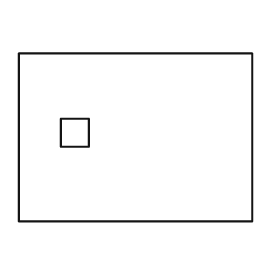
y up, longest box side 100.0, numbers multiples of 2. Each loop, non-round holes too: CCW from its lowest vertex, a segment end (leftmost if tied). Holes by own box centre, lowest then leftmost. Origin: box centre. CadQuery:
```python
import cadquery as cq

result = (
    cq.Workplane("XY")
    .moveTo(-50.0, -36.0)
    .lineTo(50.0, -36.0)
    .lineTo(50.0, 36.0)
    .lineTo(-50.0, 36.0)
    .close()
    .moveTo(-32.0, -4.0)
    .lineTo(-20.0, -4.0)
    .lineTo(-20.0, 8.0)
    .lineTo(-32.0, 8.0)
    .close()
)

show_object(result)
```